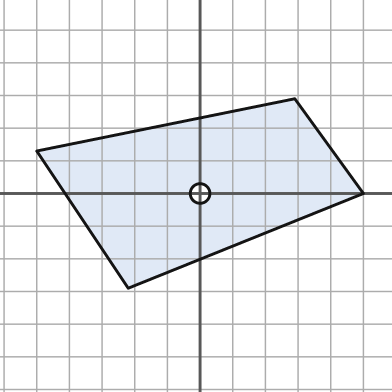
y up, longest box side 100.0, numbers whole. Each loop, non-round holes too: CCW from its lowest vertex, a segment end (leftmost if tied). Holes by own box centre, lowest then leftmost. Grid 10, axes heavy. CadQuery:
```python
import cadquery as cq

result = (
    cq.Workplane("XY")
    .moveTo(-22.0, -29.0)
    .lineTo(50.0, 0.0)
    .lineTo(29.0, 29.0)
    .lineTo(-50.0, 13.0)
    .close()
    .moveTo(0.0, 0.0)
    .circle(3.0)
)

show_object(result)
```